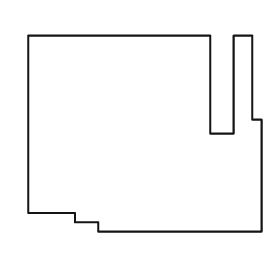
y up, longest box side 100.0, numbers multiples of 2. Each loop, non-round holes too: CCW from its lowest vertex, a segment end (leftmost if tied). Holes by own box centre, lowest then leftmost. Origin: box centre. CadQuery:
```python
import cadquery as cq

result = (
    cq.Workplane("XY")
    .moveTo(-20.0, -42.0)
    .lineTo(50.0, -42.0)
    .lineTo(50.0, 6.0)
    .lineTo(46.0, 6.0)
    .lineTo(46.0, 42.0)
    .lineTo(38.0, 42.0)
    .lineTo(38.0, 0.0)
    .lineTo(28.0, 0.0)
    .lineTo(28.0, 42.0)
    .lineTo(-50.0, 42.0)
    .lineTo(-50.0, -34.0)
    .lineTo(-30.0, -34.0)
    .lineTo(-30.0, -38.0)
    .lineTo(-20.0, -38.0)
    .close()
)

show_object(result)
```